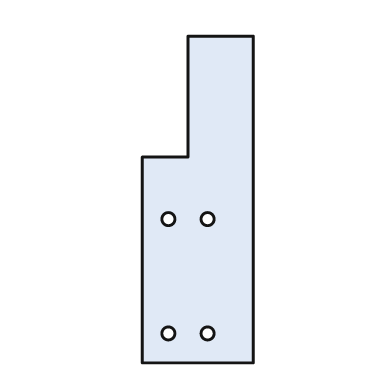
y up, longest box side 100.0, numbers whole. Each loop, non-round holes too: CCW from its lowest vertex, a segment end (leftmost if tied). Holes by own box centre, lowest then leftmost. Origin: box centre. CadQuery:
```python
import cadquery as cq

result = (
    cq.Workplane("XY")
    .moveTo(-17.0, -50.0)
    .lineTo(17.0, -50.0)
    .lineTo(17.0, 50.0)
    .lineTo(-3.0, 50.0)
    .lineTo(-3.0, 13.0)
    .lineTo(-17.0, 13.0)
    .close()
    .moveTo(-9.0, -41.0)
    .circle(2.0)
    .moveTo(3.0, -41.0)
    .circle(2.0)
    .moveTo(-9.0, -6.0)
    .circle(2.0)
    .moveTo(3.0, -6.0)
    .circle(2.0)
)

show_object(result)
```